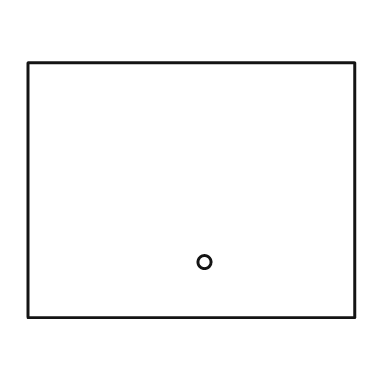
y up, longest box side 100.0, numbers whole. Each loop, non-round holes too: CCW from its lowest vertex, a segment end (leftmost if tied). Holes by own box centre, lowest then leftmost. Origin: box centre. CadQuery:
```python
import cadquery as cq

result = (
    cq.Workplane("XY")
    .moveTo(-50.0, -39.0)
    .lineTo(50.0, -39.0)
    .lineTo(50.0, 39.0)
    .lineTo(-50.0, 39.0)
    .close()
    .moveTo(4.0, -22.0)
    .circle(2.0)
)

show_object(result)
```